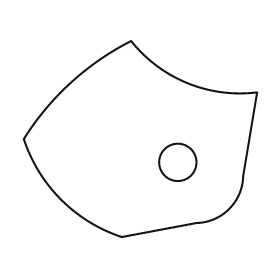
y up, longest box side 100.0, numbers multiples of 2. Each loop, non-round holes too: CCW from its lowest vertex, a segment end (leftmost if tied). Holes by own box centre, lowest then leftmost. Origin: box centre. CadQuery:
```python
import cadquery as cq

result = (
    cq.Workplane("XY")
    .moveTo(-8.0, -42.0)
    .lineTo(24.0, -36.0)
    .threePointArc((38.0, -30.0), (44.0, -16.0))
    .lineTo(50.0, 20.0)
    .threePointArc((20.0, 24.0), (-4.0, 42.0))
    .threePointArc((-30.0, 24.0), (-50.0, 0.0))
    .threePointArc((-34.0, -26.0), (-8.0, -42.0))
    .close()
    .moveTo(16.0, -10.0)
    .circle(8.0)
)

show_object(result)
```